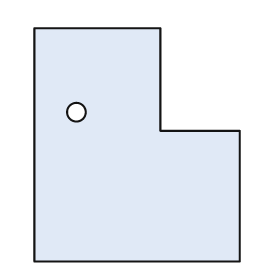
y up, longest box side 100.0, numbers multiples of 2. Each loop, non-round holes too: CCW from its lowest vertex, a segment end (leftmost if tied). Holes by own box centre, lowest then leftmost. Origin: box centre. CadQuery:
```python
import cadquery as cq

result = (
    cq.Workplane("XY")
    .moveTo(-44.0, -50.0)
    .lineTo(44.0, -50.0)
    .lineTo(44.0, 6.0)
    .lineTo(10.0, 6.0)
    .lineTo(10.0, 50.0)
    .lineTo(-44.0, 50.0)
    .close()
    .moveTo(-26.0, 14.0)
    .circle(4.0)
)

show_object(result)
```